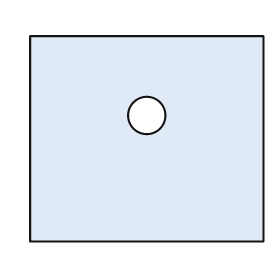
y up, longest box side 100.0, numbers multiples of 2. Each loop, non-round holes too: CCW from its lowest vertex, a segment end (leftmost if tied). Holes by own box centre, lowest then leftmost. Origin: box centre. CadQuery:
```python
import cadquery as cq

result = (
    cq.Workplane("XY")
    .moveTo(-50.0, -44.0)
    .lineTo(50.0, -44.0)
    .lineTo(50.0, 44.0)
    .lineTo(-50.0, 44.0)
    .close()
    .moveTo(0.0, 10.0)
    .circle(8.0)
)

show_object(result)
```